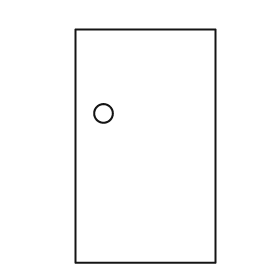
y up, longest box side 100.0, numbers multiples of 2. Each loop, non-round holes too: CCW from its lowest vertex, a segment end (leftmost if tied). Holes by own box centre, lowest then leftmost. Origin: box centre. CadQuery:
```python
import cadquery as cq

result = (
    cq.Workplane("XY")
    .moveTo(-30.0, -50.0)
    .lineTo(30.0, -50.0)
    .lineTo(30.0, 50.0)
    .lineTo(-30.0, 50.0)
    .close()
    .moveTo(-18.0, 14.0)
    .circle(4.0)
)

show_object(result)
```